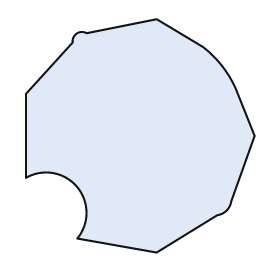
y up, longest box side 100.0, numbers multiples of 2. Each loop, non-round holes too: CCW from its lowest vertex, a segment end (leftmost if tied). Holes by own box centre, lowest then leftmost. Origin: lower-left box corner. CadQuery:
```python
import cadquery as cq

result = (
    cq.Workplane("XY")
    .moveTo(56.0, 0.0)
    .lineTo(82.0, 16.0)
    .threePointArc((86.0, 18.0), (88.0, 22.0))
    .lineTo(98.0, 50.0)
    .lineTo(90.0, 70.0)
    .threePointArc((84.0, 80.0), (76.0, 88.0))
    .lineTo(56.0, 100.0)
    .lineTo(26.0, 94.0)
    .threePointArc((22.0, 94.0), (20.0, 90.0))
    .lineTo(0.0, 68.0)
    .lineTo(0.0, 32.0)
    .threePointArc((22.0, 28.0), (22.0, 6.0))
    .close()
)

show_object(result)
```